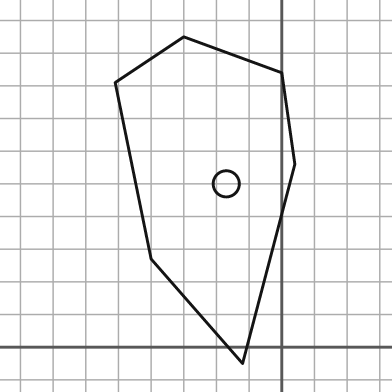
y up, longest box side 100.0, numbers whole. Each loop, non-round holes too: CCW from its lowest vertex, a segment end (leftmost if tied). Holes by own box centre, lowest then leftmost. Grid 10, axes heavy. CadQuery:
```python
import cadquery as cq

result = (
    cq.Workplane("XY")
    .moveTo(-12.0, -5.0)
    .lineTo(4.0, 56.0)
    .lineTo(0.0, 84.0)
    .lineTo(-30.0, 95.0)
    .lineTo(-51.0, 81.0)
    .lineTo(-40.0, 27.0)
    .close()
    .moveTo(-17.0, 50.0)
    .circle(4.0)
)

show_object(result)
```